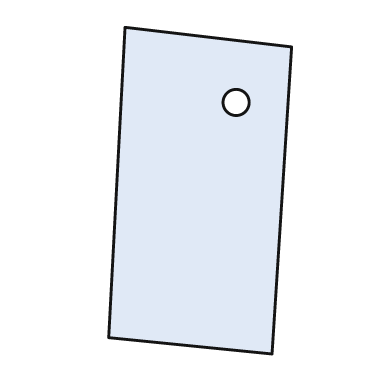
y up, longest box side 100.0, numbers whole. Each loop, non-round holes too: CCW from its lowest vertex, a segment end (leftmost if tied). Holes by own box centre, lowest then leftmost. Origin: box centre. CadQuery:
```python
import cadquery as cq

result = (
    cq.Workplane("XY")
    .moveTo(22.0, -50.0)
    .lineTo(28.0, 44.0)
    .lineTo(-23.0, 50.0)
    .lineTo(-28.0, -45.0)
    .close()
    .moveTo(11.0, 27.0)
    .circle(4.0)
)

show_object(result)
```